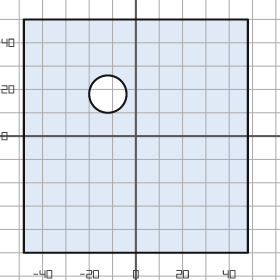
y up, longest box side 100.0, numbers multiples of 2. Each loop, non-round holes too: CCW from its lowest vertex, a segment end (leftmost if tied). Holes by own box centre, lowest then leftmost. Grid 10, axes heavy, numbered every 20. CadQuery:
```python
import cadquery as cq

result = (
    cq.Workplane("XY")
    .moveTo(-48.0, -50.0)
    .lineTo(48.0, -50.0)
    .lineTo(48.0, 50.0)
    .lineTo(-48.0, 50.0)
    .close()
    .moveTo(-12.0, 18.0)
    .circle(8.0)
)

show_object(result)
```